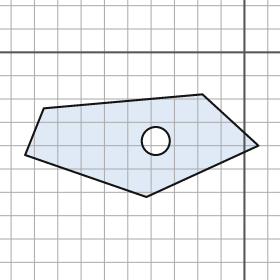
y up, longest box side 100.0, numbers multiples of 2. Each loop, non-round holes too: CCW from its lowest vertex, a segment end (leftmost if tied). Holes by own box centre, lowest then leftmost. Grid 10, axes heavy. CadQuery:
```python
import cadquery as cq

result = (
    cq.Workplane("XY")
    .moveTo(-42.0, -62.0)
    .lineTo(6.0, -40.0)
    .lineTo(-18.0, -18.0)
    .lineTo(-86.0, -24.0)
    .lineTo(-94.0, -44.0)
    .close()
    .moveTo(-38.0, -38.0)
    .circle(6.0)
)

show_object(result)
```